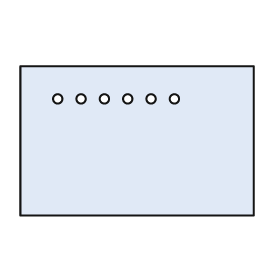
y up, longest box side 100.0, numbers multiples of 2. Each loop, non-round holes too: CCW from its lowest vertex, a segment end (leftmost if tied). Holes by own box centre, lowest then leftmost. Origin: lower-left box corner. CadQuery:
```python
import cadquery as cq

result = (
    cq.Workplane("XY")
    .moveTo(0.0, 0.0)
    .lineTo(100.0, 0.0)
    .lineTo(100.0, 64.0)
    .lineTo(0.0, 64.0)
    .close()
    .moveTo(16.0, 50.0)
    .circle(2.0)
    .moveTo(26.0, 50.0)
    .circle(2.0)
    .moveTo(36.0, 50.0)
    .circle(2.0)
    .moveTo(46.0, 50.0)
    .circle(2.0)
    .moveTo(56.0, 50.0)
    .circle(2.0)
    .moveTo(66.0, 50.0)
    .circle(2.0)
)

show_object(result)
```